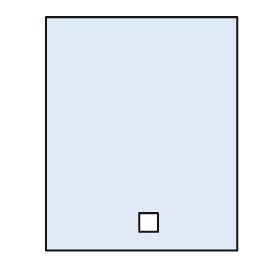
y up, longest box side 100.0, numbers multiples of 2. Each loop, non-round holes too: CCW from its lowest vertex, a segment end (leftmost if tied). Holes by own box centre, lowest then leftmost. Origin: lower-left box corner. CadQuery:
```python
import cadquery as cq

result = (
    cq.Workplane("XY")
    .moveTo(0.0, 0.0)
    .lineTo(82.0, 0.0)
    .lineTo(82.0, 100.0)
    .lineTo(0.0, 100.0)
    .close()
    .moveTo(40.0, 8.0)
    .lineTo(48.0, 8.0)
    .lineTo(48.0, 16.0)
    .lineTo(40.0, 16.0)
    .close()
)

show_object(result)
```